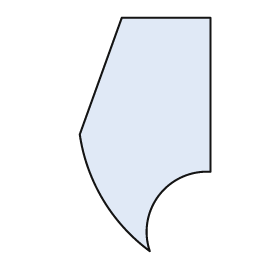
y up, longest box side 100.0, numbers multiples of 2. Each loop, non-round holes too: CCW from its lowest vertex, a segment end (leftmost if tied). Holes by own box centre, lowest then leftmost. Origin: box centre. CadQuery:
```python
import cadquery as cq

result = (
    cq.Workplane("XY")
    .moveTo(2.0, -50.0)
    .threePointArc((6.0, -26.0), (28.0, -16.0))
    .lineTo(28.0, 50.0)
    .lineTo(-10.0, 50.0)
    .lineTo(-28.0, 0.0)
    .threePointArc((-18.0, -28.0), (2.0, -50.0))
    .close()
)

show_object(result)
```